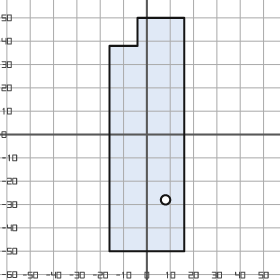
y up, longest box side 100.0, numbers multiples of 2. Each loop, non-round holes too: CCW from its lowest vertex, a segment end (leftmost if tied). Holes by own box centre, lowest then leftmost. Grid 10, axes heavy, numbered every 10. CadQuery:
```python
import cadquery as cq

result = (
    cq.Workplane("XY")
    .moveTo(-16.0, -50.0)
    .lineTo(16.0, -50.0)
    .lineTo(16.0, 50.0)
    .lineTo(-4.0, 50.0)
    .lineTo(-4.0, 38.0)
    .lineTo(-16.0, 38.0)
    .close()
    .moveTo(8.0, -28.0)
    .circle(2.0)
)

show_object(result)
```